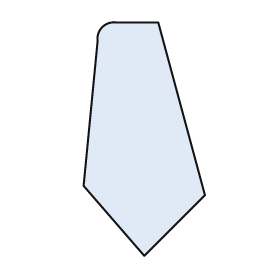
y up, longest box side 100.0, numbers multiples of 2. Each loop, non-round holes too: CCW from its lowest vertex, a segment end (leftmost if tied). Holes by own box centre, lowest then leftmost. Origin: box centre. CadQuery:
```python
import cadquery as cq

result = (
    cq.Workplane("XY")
    .moveTo(0.0, -50.0)
    .lineTo(26.0, -24.0)
    .lineTo(6.0, 50.0)
    .lineTo(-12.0, 50.0)
    .threePointArc((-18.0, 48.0), (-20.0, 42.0))
    .lineTo(-26.0, -20.0)
    .close()
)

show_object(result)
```